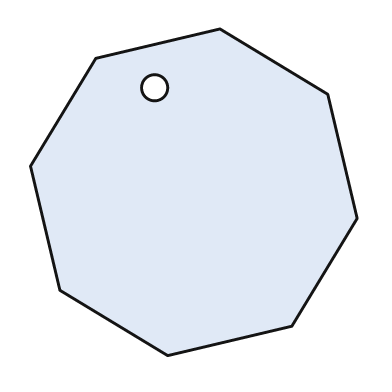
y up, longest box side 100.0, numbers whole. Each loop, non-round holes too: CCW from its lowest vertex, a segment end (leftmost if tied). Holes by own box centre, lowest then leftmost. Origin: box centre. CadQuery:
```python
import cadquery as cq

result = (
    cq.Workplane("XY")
    .moveTo(-8.0, -50.0)
    .lineTo(30.0, -41.0)
    .lineTo(50.0, -8.0)
    .lineTo(41.0, 30.0)
    .lineTo(8.0, 50.0)
    .lineTo(-30.0, 41.0)
    .lineTo(-50.0, 8.0)
    .lineTo(-41.0, -30.0)
    .close()
    .moveTo(-12.0, 32.0)
    .circle(4.0)
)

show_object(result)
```